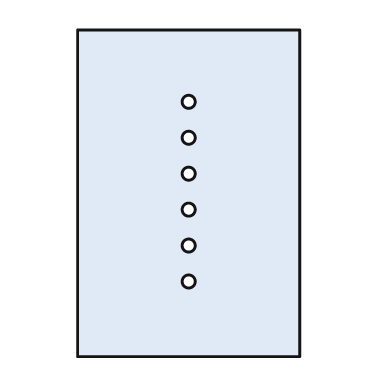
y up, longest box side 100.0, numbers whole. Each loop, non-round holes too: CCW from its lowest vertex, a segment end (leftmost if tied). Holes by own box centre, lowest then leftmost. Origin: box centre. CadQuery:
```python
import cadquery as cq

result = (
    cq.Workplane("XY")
    .moveTo(-34.0, -50.0)
    .lineTo(34.0, -50.0)
    .lineTo(34.0, 50.0)
    .lineTo(-34.0, 50.0)
    .close()
    .moveTo(0.0, -27.0)
    .circle(2.0)
    .moveTo(0.0, -16.0)
    .circle(2.0)
    .moveTo(0.0, -5.0)
    .circle(2.0)
    .moveTo(0.0, 6.0)
    .circle(2.0)
    .moveTo(0.0, 17.0)
    .circle(2.0)
    .moveTo(0.0, 28.0)
    .circle(2.0)
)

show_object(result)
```